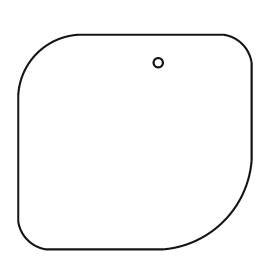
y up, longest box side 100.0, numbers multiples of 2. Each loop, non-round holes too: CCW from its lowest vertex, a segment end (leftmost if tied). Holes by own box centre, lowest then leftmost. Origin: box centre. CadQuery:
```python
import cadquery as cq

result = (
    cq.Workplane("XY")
    .moveTo(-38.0, -46.0)
    .lineTo(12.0, -46.0)
    .threePointArc((38.0, -34.0), (50.0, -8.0))
    .lineTo(50.0, 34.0)
    .threePointArc((46.0, 42.0), (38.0, 46.0))
    .lineTo(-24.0, 46.0)
    .threePointArc((-42.0, 38.0), (-50.0, 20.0))
    .lineTo(-50.0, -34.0)
    .threePointArc((-46.0, -42.0), (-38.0, -46.0))
    .close()
    .moveTo(10.0, 34.0)
    .circle(2.0)
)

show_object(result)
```